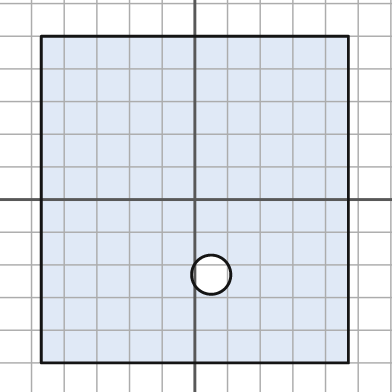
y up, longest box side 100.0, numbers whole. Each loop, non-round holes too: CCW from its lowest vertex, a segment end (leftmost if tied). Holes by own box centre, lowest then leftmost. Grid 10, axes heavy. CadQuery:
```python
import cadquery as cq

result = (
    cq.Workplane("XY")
    .moveTo(-47.0, -50.0)
    .lineTo(47.0, -50.0)
    .lineTo(47.0, 50.0)
    .lineTo(-47.0, 50.0)
    .close()
    .moveTo(5.0, -23.0)
    .circle(6.0)
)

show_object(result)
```